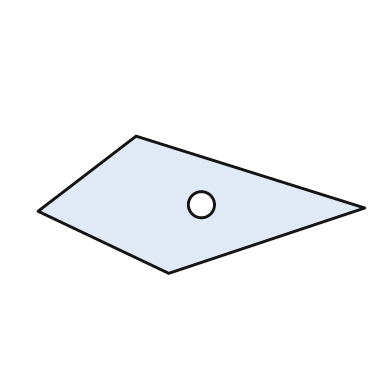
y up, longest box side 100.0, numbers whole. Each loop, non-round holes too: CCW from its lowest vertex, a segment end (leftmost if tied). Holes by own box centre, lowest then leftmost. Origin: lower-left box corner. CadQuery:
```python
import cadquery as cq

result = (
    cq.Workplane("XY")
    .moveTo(40.0, 0.0)
    .lineTo(100.0, 20.0)
    .lineTo(30.0, 42.0)
    .lineTo(0.0, 19.0)
    .close()
    .moveTo(50.0, 21.0)
    .circle(4.0)
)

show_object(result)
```